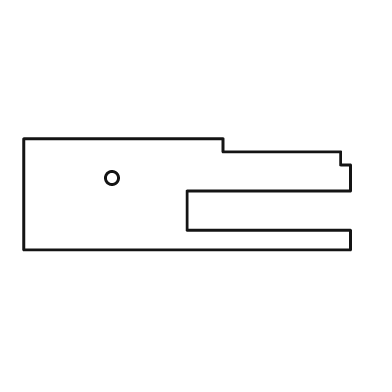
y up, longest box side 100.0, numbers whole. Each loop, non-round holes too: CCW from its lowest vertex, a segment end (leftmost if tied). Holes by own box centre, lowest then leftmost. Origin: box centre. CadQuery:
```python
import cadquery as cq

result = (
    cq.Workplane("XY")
    .moveTo(-50.0, -17.0)
    .lineTo(50.0, -17.0)
    .lineTo(50.0, -11.0)
    .lineTo(0.0, -11.0)
    .lineTo(0.0, 1.0)
    .lineTo(50.0, 1.0)
    .lineTo(50.0, 9.0)
    .lineTo(47.0, 9.0)
    .lineTo(47.0, 13.0)
    .lineTo(11.0, 13.0)
    .lineTo(11.0, 17.0)
    .lineTo(-50.0, 17.0)
    .close()
    .moveTo(-23.0, 5.0)
    .circle(2.0)
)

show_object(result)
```